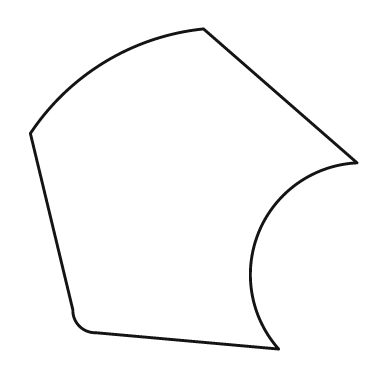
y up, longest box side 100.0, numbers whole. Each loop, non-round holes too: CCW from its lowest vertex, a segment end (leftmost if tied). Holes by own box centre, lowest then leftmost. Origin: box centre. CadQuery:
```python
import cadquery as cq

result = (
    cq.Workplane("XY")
    .moveTo(26.0, -49.0)
    .threePointArc((20.0, -13.0), (50.0, 8.0))
    .lineTo(3.0, 49.0)
    .threePointArc((-27.0, 39.0), (-50.0, 17.0))
    .lineTo(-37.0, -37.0)
    .threePointArc((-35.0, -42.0), (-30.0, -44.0))
    .close()
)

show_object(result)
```